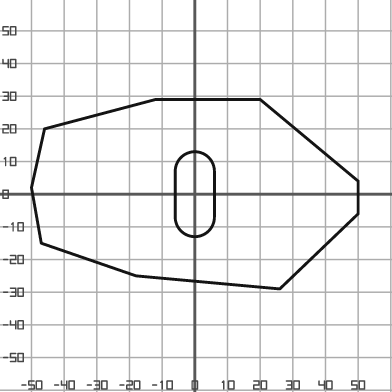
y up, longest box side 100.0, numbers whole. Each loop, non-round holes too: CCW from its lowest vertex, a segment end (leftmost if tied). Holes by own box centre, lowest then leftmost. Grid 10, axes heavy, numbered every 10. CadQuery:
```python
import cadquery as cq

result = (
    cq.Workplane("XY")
    .moveTo(26.0, -29.0)
    .lineTo(50.0, -6.0)
    .lineTo(50.0, 4.0)
    .lineTo(20.0, 29.0)
    .lineTo(-12.0, 29.0)
    .lineTo(-46.0, 20.0)
    .lineTo(-50.0, 2.0)
    .lineTo(-47.0, -15.0)
    .lineTo(-18.0, -25.0)
    .close()
    .moveTo(-6.0, -7.0)
    .threePointArc((0.0, -13.0), (6.0, -7.0))
    .lineTo(6.0, 7.0)
    .threePointArc((0.0, 13.0), (-6.0, 7.0))
    .close()
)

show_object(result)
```